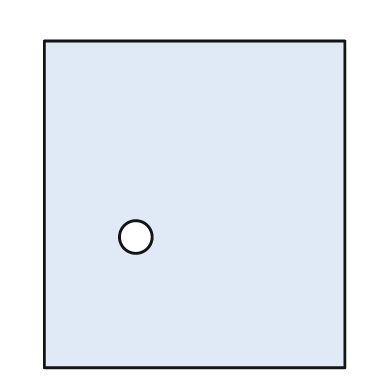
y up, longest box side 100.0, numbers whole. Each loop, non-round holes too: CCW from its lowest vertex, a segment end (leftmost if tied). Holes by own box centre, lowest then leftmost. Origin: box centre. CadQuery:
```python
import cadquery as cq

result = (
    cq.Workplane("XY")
    .moveTo(-46.0, -50.0)
    .lineTo(46.0, -50.0)
    .lineTo(46.0, 50.0)
    .lineTo(-46.0, 50.0)
    .close()
    .moveTo(-18.0, -10.0)
    .circle(5.0)
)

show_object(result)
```